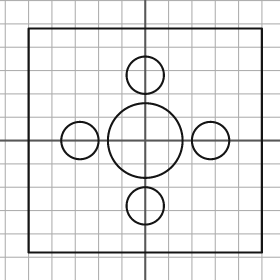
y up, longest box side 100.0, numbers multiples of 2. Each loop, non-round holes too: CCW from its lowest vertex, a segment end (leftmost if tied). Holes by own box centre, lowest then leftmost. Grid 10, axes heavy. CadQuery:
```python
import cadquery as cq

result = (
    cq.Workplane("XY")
    .moveTo(-50.0, -48.0)
    .lineTo(50.0, -48.0)
    .lineTo(50.0, 48.0)
    .lineTo(-50.0, 48.0)
    .close()
    .moveTo(0.0, -28.0)
    .circle(8.0)
    .moveTo(-28.0, 0.0)
    .circle(8.0)
    .moveTo(0.0, 0.0)
    .circle(16.0)
    .moveTo(28.0, 0.0)
    .circle(8.0)
    .moveTo(0.0, 28.0)
    .circle(8.0)
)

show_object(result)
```